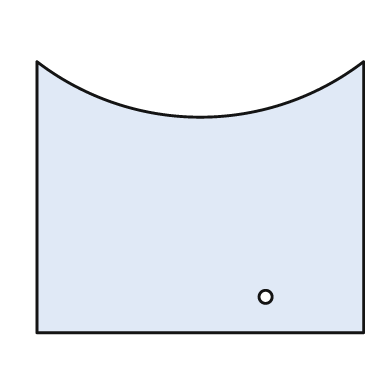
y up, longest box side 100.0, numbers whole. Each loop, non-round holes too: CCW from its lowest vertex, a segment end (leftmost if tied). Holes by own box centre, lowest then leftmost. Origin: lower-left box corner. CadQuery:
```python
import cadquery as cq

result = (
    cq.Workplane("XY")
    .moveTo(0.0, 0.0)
    .lineTo(100.0, 0.0)
    .lineTo(100.0, 83.0)
    .threePointArc((50.0, 66.0), (0.0, 83.0))
    .close()
    .moveTo(70.0, 11.0)
    .circle(2.0)
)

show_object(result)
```